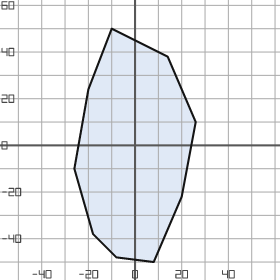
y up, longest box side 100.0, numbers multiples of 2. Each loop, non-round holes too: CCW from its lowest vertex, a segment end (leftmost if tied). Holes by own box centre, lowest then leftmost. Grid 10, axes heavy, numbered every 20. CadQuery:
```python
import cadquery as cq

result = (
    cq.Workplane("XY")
    .moveTo(8.0, -50.0)
    .lineTo(20.0, -22.0)
    .lineTo(26.0, 10.0)
    .lineTo(14.0, 38.0)
    .lineTo(-10.0, 50.0)
    .lineTo(-20.0, 24.0)
    .lineTo(-26.0, -10.0)
    .lineTo(-18.0, -38.0)
    .lineTo(-8.0, -48.0)
    .close()
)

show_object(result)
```